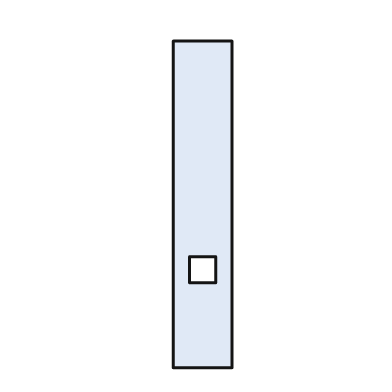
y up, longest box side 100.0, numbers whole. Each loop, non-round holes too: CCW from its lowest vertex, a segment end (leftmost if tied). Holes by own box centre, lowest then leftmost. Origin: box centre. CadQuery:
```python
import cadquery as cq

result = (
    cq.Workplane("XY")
    .moveTo(-9.0, -50.0)
    .lineTo(9.0, -50.0)
    .lineTo(9.0, 50.0)
    .lineTo(-9.0, 50.0)
    .close()
    .moveTo(-4.0, -24.0)
    .lineTo(4.0, -24.0)
    .lineTo(4.0, -16.0)
    .lineTo(-4.0, -16.0)
    .close()
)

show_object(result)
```